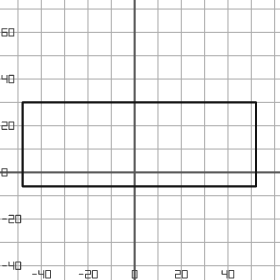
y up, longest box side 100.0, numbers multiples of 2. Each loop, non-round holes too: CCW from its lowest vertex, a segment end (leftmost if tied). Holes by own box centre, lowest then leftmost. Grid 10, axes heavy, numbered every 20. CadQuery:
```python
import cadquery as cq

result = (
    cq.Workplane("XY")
    .moveTo(-48.0, -6.0)
    .lineTo(52.0, -6.0)
    .lineTo(52.0, 30.0)
    .lineTo(-48.0, 30.0)
    .close()
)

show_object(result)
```